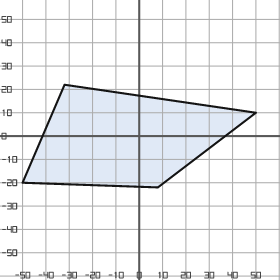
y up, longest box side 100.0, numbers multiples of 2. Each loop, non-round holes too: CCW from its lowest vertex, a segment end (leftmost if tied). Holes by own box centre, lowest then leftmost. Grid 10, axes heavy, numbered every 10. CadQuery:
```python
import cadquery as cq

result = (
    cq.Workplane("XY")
    .moveTo(8.0, -22.0)
    .lineTo(50.0, 10.0)
    .lineTo(-32.0, 22.0)
    .lineTo(-50.0, -20.0)
    .close()
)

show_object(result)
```